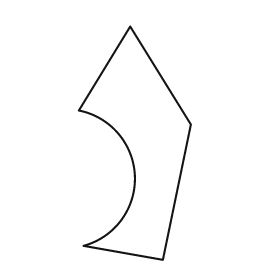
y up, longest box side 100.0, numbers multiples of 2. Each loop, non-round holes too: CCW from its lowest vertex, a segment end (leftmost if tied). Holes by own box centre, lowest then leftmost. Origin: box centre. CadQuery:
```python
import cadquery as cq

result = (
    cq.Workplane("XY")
    .moveTo(12.0, -50.0)
    .lineTo(24.0, 8.0)
    .lineTo(-2.0, 50.0)
    .lineTo(-24.0, 14.0)
    .threePointArc((0.0, -14.0), (-22.0, -44.0))
    .close()
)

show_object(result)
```